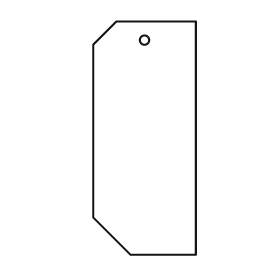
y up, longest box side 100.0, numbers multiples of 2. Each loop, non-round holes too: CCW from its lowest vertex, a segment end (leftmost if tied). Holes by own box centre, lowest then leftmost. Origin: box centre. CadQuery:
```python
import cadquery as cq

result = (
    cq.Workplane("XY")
    .moveTo(-6.0, -50.0)
    .lineTo(22.0, -50.0)
    .lineTo(22.0, 50.0)
    .lineTo(-12.0, 50.0)
    .lineTo(-22.0, 40.0)
    .lineTo(-22.0, -34.0)
    .close()
    .moveTo(0.0, 42.0)
    .circle(2.0)
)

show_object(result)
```